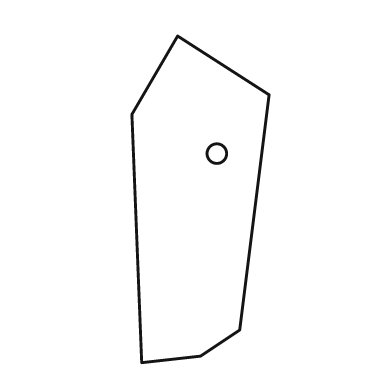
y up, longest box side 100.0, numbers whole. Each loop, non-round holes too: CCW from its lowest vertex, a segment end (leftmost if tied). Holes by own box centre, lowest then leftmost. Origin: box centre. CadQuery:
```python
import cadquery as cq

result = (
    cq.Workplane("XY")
    .moveTo(-18.0, -50.0)
    .lineTo(0.0, -48.0)
    .lineTo(12.0, -40.0)
    .lineTo(21.0, 32.0)
    .lineTo(-7.0, 50.0)
    .lineTo(-21.0, 26.0)
    .close()
    .moveTo(5.0, 14.0)
    .circle(3.0)
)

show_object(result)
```